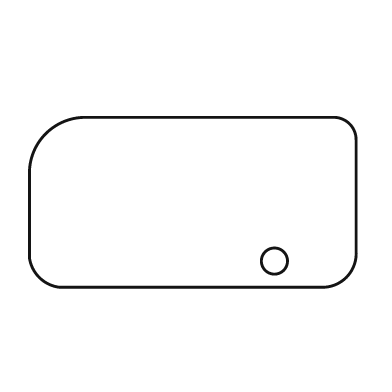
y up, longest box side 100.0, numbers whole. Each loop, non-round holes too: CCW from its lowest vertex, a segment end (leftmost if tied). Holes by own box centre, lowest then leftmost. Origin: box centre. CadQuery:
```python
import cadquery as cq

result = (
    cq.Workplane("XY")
    .moveTo(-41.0, -26.0)
    .lineTo(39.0, -26.0)
    .threePointArc((47.0, -23.0), (50.0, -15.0))
    .lineTo(50.0, 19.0)
    .threePointArc((48.0, 24.0), (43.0, 26.0))
    .lineTo(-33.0, 26.0)
    .threePointArc((-45.0, 21.0), (-50.0, 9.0))
    .lineTo(-50.0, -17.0)
    .threePointArc((-47.0, -23.0), (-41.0, -26.0))
    .close()
    .moveTo(25.0, -18.0)
    .circle(4.0)
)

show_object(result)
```